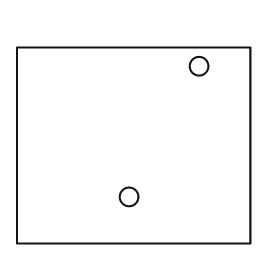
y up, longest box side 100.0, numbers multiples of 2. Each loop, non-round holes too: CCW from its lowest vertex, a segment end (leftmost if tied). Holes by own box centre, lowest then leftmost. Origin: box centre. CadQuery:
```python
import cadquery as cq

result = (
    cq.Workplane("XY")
    .moveTo(-50.0, -42.0)
    .lineTo(50.0, -42.0)
    .lineTo(50.0, 42.0)
    .lineTo(-50.0, 42.0)
    .close()
    .moveTo(-2.0, -22.0)
    .circle(4.0)
    .moveTo(28.0, 34.0)
    .circle(4.0)
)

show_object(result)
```